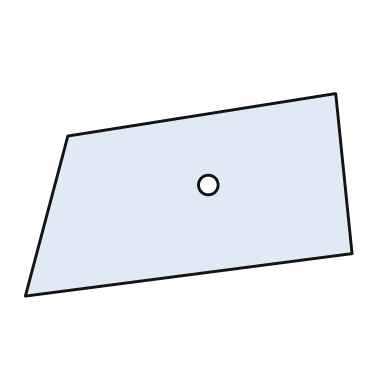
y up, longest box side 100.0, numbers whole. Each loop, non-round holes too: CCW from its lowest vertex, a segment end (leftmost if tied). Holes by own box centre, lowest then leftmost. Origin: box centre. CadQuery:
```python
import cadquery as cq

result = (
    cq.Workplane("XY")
    .moveTo(-50.0, -31.0)
    .lineTo(50.0, -18.0)
    .lineTo(45.0, 31.0)
    .lineTo(-37.0, 18.0)
    .close()
    .moveTo(6.0, 3.0)
    .circle(3.0)
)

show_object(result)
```